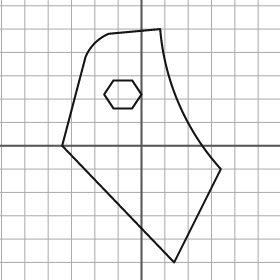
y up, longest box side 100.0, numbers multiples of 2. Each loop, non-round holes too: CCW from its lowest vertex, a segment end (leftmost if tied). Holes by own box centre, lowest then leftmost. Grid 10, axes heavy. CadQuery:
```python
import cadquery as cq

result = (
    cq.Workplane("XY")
    .moveTo(14.0, -50.0)
    .lineTo(34.0, -10.0)
    .threePointArc((16.0, 18.0), (8.0, 50.0))
    .lineTo(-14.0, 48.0)
    .threePointArc((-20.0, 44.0), (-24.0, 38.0))
    .lineTo(-34.0, 0.0)
    .close()
    .moveTo(-12.0, 16.0)
    .lineTo(-4.0, 16.0)
    .lineTo(0.0, 22.0)
    .lineTo(-4.0, 28.0)
    .lineTo(-12.0, 28.0)
    .lineTo(-16.0, 22.0)
    .close()
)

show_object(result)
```